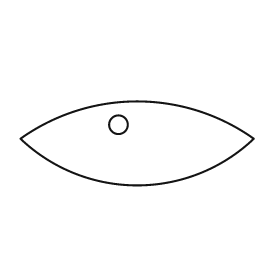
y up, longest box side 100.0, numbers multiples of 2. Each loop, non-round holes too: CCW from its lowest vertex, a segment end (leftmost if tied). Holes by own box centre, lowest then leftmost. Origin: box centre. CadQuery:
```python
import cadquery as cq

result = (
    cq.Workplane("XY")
    .moveTo(-50.0, 2.0)
    .threePointArc((0.0, -18.0), (50.0, 2.0))
    .threePointArc((0.0, 18.0), (-50.0, 2.0))
    .close()
    .moveTo(-8.0, 8.0)
    .circle(4.0)
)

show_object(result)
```